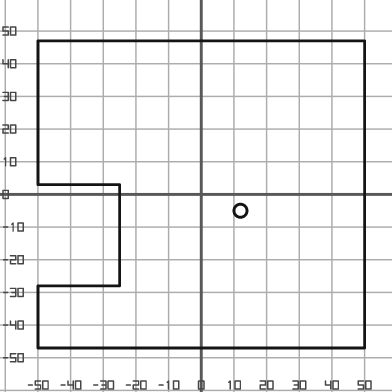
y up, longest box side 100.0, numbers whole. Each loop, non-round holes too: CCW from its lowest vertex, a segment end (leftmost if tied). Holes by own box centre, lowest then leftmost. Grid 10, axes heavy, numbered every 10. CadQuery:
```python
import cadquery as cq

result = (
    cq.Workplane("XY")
    .moveTo(-50.0, -47.0)
    .lineTo(50.0, -47.0)
    .lineTo(50.0, 47.0)
    .lineTo(-50.0, 47.0)
    .lineTo(-50.0, 3.0)
    .lineTo(-25.0, 3.0)
    .lineTo(-25.0, -28.0)
    .lineTo(-50.0, -28.0)
    .close()
    .moveTo(12.0, -5.0)
    .circle(2.0)
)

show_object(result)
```